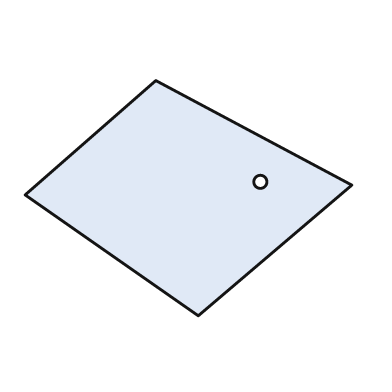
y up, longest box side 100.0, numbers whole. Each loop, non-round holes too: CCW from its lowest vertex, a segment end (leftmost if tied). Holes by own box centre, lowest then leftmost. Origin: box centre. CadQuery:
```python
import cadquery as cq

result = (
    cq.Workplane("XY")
    .moveTo(3.0, -36.0)
    .lineTo(50.0, 4.0)
    .lineTo(-10.0, 36.0)
    .lineTo(-50.0, 1.0)
    .close()
    .moveTo(22.0, 5.0)
    .circle(2.0)
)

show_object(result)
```